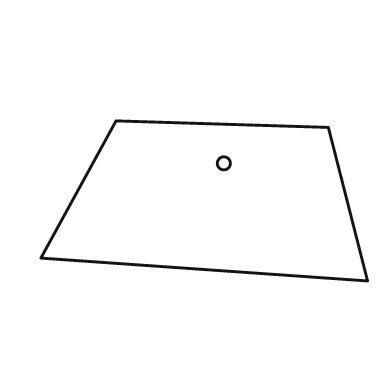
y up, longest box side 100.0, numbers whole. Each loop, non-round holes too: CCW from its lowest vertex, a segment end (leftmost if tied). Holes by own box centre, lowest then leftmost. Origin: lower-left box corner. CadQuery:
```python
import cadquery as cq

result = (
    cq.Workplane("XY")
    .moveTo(100.0, 0.0)
    .lineTo(88.0, 47.0)
    .lineTo(23.0, 49.0)
    .lineTo(0.0, 7.0)
    .close()
    .moveTo(56.0, 36.0)
    .circle(2.0)
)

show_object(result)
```